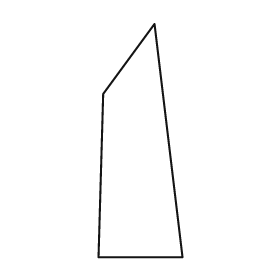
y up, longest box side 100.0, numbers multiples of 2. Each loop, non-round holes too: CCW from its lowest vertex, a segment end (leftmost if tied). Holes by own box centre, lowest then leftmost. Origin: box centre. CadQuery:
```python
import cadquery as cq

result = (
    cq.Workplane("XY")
    .moveTo(-18.0, -50.0)
    .lineTo(18.0, -50.0)
    .lineTo(6.0, 50.0)
    .lineTo(-16.0, 20.0)
    .close()
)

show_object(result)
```